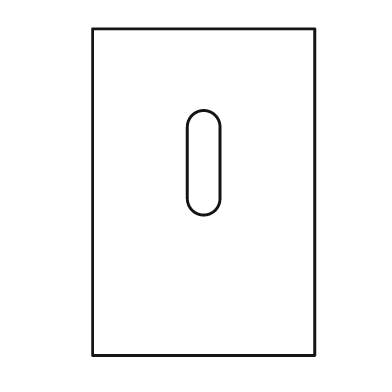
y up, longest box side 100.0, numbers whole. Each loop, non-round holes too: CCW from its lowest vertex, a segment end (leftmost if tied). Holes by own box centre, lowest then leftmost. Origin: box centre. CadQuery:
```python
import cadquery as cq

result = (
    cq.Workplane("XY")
    .moveTo(-34.0, -50.0)
    .lineTo(34.0, -50.0)
    .lineTo(34.0, 50.0)
    .lineTo(-34.0, 50.0)
    .close()
    .moveTo(-5.0, -2.0)
    .threePointArc((0.0, -7.0), (5.0, -2.0))
    .lineTo(5.0, 20.0)
    .threePointArc((0.0, 25.0), (-5.0, 20.0))
    .close()
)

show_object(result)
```